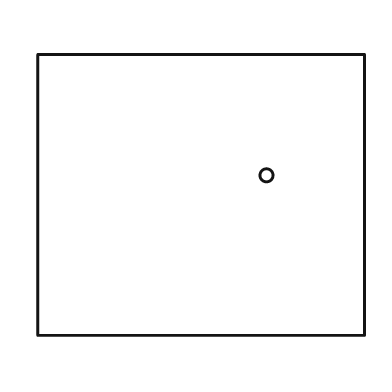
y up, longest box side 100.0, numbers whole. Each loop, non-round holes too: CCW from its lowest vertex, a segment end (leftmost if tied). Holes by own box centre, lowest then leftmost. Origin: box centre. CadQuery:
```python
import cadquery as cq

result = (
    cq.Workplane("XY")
    .moveTo(-50.0, -43.0)
    .lineTo(50.0, -43.0)
    .lineTo(50.0, 43.0)
    .lineTo(-50.0, 43.0)
    .close()
    .moveTo(20.0, 6.0)
    .circle(2.0)
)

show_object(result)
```